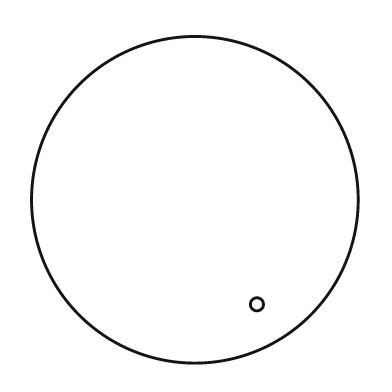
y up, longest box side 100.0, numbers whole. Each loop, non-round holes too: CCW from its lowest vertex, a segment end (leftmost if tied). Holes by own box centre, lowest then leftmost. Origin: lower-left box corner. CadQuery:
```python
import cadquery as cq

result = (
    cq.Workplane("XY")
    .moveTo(50.0, 50.0)
    .circle(50.0)
    .moveTo(69.0, 18.0)
    .circle(2.0)
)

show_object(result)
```